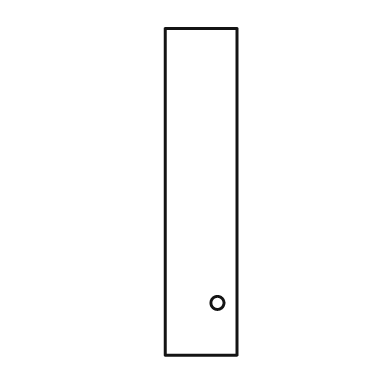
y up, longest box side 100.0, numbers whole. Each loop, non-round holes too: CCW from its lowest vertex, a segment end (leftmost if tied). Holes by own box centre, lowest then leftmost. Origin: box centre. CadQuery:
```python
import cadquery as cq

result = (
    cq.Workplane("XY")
    .moveTo(-11.0, -50.0)
    .lineTo(11.0, -50.0)
    .lineTo(11.0, 50.0)
    .lineTo(-11.0, 50.0)
    .close()
    .moveTo(5.0, -34.0)
    .circle(2.0)
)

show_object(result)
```